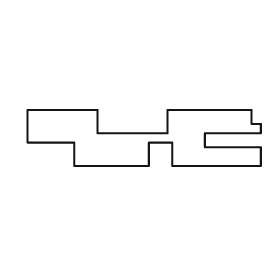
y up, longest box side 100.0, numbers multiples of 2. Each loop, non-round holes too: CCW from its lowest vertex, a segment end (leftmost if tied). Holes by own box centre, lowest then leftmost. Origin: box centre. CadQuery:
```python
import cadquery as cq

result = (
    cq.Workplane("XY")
    .moveTo(-30.0, -12.0)
    .lineTo(2.0, -12.0)
    .lineTo(2.0, -2.0)
    .lineTo(12.0, -2.0)
    .lineTo(12.0, -12.0)
    .lineTo(50.0, -12.0)
    .lineTo(50.0, -4.0)
    .lineTo(26.0, -4.0)
    .lineTo(26.0, 2.0)
    .lineTo(50.0, 2.0)
    .lineTo(50.0, 6.0)
    .lineTo(46.0, 6.0)
    .lineTo(46.0, 12.0)
    .lineTo(10.0, 12.0)
    .lineTo(10.0, 2.0)
    .lineTo(-20.0, 2.0)
    .lineTo(-20.0, 12.0)
    .lineTo(-50.0, 12.0)
    .lineTo(-50.0, -2.0)
    .lineTo(-30.0, -2.0)
    .close()
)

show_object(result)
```